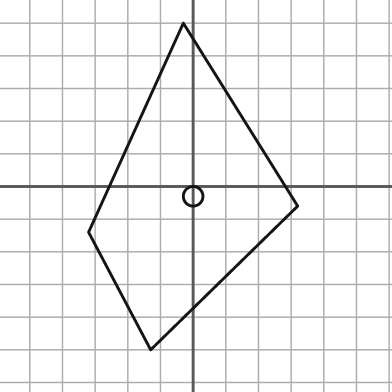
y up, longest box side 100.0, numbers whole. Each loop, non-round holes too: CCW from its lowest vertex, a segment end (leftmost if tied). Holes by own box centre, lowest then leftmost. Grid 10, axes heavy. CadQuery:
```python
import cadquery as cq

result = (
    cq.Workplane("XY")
    .moveTo(-13.0, -50.0)
    .lineTo(32.0, -6.0)
    .lineTo(-3.0, 50.0)
    .lineTo(-32.0, -14.0)
    .close()
    .moveTo(0.0, -3.0)
    .circle(3.0)
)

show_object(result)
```